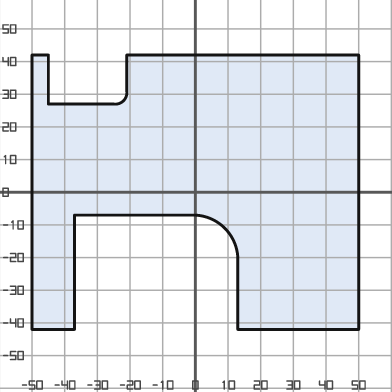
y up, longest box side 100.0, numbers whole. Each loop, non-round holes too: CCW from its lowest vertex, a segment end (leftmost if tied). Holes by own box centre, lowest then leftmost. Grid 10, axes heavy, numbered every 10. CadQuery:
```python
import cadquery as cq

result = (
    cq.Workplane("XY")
    .moveTo(-50.0, -42.0)
    .lineTo(-37.0, -42.0)
    .lineTo(-37.0, -7.0)
    .lineTo(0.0, -7.0)
    .threePointArc((9.0, -11.0), (13.0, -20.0))
    .lineTo(13.0, -42.0)
    .lineTo(50.0, -42.0)
    .lineTo(50.0, 42.0)
    .lineTo(-21.0, 42.0)
    .lineTo(-21.0, 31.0)
    .threePointArc((-22.0, 28.0), (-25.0, 27.0))
    .lineTo(-45.0, 27.0)
    .lineTo(-45.0, 42.0)
    .lineTo(-50.0, 42.0)
    .close()
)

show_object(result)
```